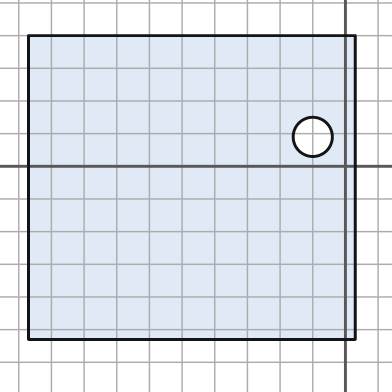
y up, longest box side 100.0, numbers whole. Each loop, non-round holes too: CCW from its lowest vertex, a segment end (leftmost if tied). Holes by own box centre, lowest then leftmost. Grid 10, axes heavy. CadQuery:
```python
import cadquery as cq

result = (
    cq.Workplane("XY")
    .moveTo(-97.0, -53.0)
    .lineTo(3.0, -53.0)
    .lineTo(3.0, 40.0)
    .lineTo(-97.0, 40.0)
    .close()
    .moveTo(-10.0, 9.0)
    .circle(6.0)
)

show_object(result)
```